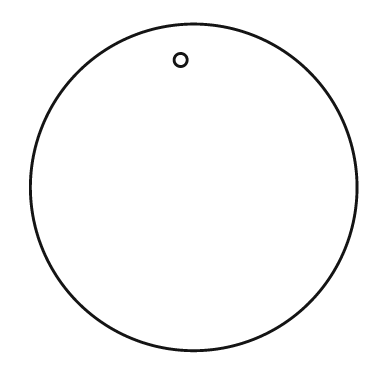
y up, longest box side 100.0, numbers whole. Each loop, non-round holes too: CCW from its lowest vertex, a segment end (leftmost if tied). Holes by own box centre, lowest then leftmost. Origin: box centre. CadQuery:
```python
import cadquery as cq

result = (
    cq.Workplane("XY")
    .moveTo(0.0, 0.0)
    .circle(50.0)
    .moveTo(-4.0, 39.0)
    .circle(2.0)
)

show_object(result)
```